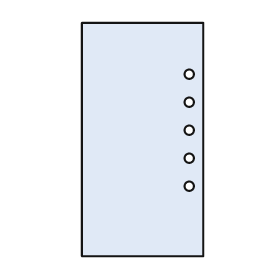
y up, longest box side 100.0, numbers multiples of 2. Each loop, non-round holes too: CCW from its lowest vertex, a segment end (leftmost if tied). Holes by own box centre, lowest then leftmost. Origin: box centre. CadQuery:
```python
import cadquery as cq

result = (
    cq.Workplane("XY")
    .moveTo(-26.0, -50.0)
    .lineTo(26.0, -50.0)
    .lineTo(26.0, 50.0)
    .lineTo(-26.0, 50.0)
    .close()
    .moveTo(20.0, -20.0)
    .circle(2.0)
    .moveTo(20.0, -8.0)
    .circle(2.0)
    .moveTo(20.0, 4.0)
    .circle(2.0)
    .moveTo(20.0, 16.0)
    .circle(2.0)
    .moveTo(20.0, 28.0)
    .circle(2.0)
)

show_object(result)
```